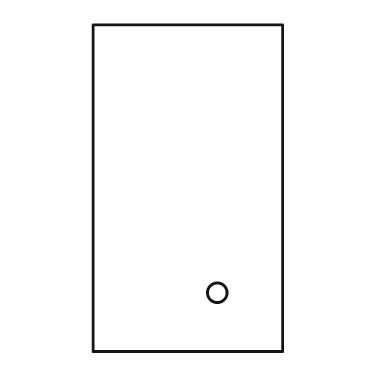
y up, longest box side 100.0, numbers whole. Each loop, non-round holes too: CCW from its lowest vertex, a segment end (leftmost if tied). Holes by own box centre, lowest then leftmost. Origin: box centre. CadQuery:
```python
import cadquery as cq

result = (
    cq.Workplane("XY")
    .moveTo(-29.0, -50.0)
    .lineTo(29.0, -50.0)
    .lineTo(29.0, 50.0)
    .lineTo(-29.0, 50.0)
    .close()
    .moveTo(9.0, -32.0)
    .circle(3.0)
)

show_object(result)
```